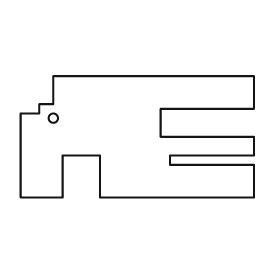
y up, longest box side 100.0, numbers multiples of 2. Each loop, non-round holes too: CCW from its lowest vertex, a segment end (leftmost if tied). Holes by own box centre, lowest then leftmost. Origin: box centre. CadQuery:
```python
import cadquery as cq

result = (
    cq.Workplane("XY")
    .moveTo(-50.0, -26.0)
    .lineTo(-32.0, -26.0)
    .lineTo(-32.0, -8.0)
    .lineTo(-16.0, -8.0)
    .lineTo(-16.0, -26.0)
    .lineTo(50.0, -26.0)
    .lineTo(50.0, -12.0)
    .lineTo(14.0, -12.0)
    .lineTo(14.0, -8.0)
    .lineTo(50.0, -8.0)
    .lineTo(50.0, 0.0)
    .lineTo(10.0, 0.0)
    .lineTo(10.0, 12.0)
    .lineTo(50.0, 12.0)
    .lineTo(50.0, 26.0)
    .lineTo(-36.0, 26.0)
    .lineTo(-36.0, 14.0)
    .lineTo(-42.0, 14.0)
    .lineTo(-42.0, 10.0)
    .lineTo(-50.0, 10.0)
    .close()
    .moveTo(-36.0, 8.0)
    .circle(2.0)
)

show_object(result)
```